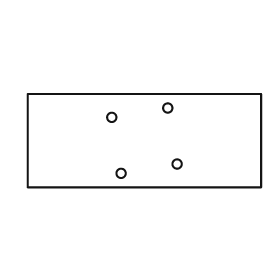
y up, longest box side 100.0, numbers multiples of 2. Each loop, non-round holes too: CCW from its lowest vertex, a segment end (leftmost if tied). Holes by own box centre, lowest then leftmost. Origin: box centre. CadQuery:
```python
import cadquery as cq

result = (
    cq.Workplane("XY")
    .moveTo(-50.0, -20.0)
    .lineTo(50.0, -20.0)
    .lineTo(50.0, 20.0)
    .lineTo(-50.0, 20.0)
    .close()
    .moveTo(-10.0, -14.0)
    .circle(2.0)
    .moveTo(14.0, -10.0)
    .circle(2.0)
    .moveTo(-14.0, 10.0)
    .circle(2.0)
    .moveTo(10.0, 14.0)
    .circle(2.0)
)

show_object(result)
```